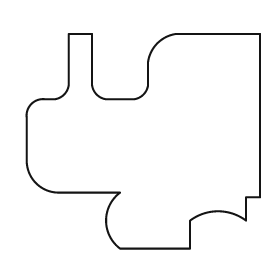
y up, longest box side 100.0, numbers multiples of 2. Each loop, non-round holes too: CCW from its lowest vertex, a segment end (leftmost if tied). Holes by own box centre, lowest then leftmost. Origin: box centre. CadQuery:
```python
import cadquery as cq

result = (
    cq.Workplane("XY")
    .moveTo(-10.0, -46.0)
    .lineTo(20.0, -46.0)
    .lineTo(20.0, -34.0)
    .threePointArc((32.0, -30.0), (44.0, -34.0))
    .lineTo(44.0, -24.0)
    .lineTo(50.0, -24.0)
    .lineTo(50.0, 46.0)
    .lineTo(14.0, 46.0)
    .threePointArc((6.0, 42.0), (2.0, 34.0))
    .lineTo(2.0, 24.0)
    .threePointArc((0.0, 20.0), (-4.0, 18.0))
    .lineTo(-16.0, 18.0)
    .threePointArc((-20.0, 20.0), (-22.0, 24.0))
    .lineTo(-22.0, 46.0)
    .lineTo(-32.0, 46.0)
    .lineTo(-32.0, 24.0)
    .threePointArc((-34.0, 20.0), (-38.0, 18.0))
    .lineTo(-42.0, 18.0)
    .threePointArc((-48.0, 16.0), (-50.0, 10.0))
    .lineTo(-50.0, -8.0)
    .threePointArc((-46.0, -18.0), (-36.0, -22.0))
    .lineTo(-10.0, -22.0)
    .threePointArc((-16.0, -34.0), (-10.0, -46.0))
    .close()
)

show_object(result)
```